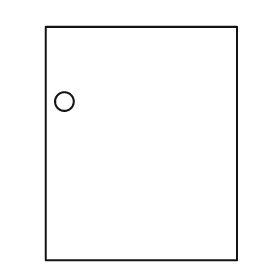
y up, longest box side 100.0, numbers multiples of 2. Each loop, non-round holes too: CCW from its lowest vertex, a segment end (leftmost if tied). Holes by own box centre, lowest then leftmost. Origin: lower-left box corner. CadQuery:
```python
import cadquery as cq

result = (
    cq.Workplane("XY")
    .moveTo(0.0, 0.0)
    .lineTo(82.0, 0.0)
    .lineTo(82.0, 100.0)
    .lineTo(0.0, 100.0)
    .close()
    .moveTo(8.0, 68.0)
    .circle(4.0)
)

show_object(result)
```